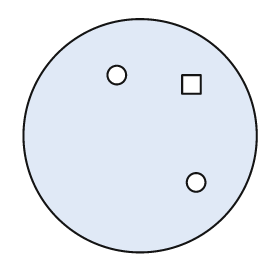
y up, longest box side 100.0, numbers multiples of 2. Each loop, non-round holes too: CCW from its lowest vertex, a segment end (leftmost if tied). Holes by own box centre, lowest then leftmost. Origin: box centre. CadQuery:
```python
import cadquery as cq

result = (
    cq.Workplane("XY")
    .moveTo(0.0, 0.0)
    .circle(50.0)
    .moveTo(24.0, -20.0)
    .circle(4.0)
    .moveTo(18.0, 18.0)
    .lineTo(26.0, 18.0)
    .lineTo(26.0, 26.0)
    .lineTo(18.0, 26.0)
    .close()
    .moveTo(-10.0, 26.0)
    .circle(4.0)
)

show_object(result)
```